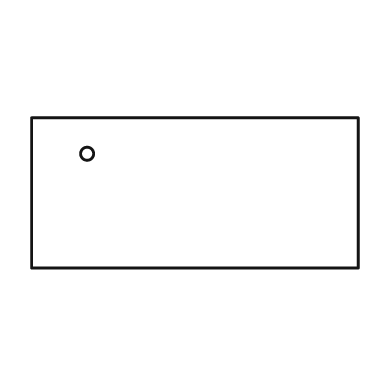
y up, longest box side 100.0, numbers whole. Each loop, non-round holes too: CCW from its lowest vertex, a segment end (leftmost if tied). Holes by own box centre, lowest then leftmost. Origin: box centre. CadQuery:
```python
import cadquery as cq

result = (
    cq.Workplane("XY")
    .moveTo(-50.0, -23.0)
    .lineTo(50.0, -23.0)
    .lineTo(50.0, 23.0)
    .lineTo(-50.0, 23.0)
    .close()
    .moveTo(-33.0, 12.0)
    .circle(2.0)
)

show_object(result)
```